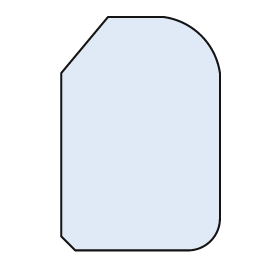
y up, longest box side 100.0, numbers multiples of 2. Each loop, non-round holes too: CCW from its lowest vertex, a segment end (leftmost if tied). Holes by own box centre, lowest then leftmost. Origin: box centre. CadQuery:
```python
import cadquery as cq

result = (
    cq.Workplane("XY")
    .moveTo(-28.0, -50.0)
    .lineTo(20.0, -50.0)
    .threePointArc((30.0, -46.0), (34.0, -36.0))
    .lineTo(34.0, 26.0)
    .threePointArc((26.0, 42.0), (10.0, 50.0))
    .lineTo(-14.0, 50.0)
    .lineTo(-34.0, 26.0)
    .lineTo(-34.0, -44.0)
    .close()
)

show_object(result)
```